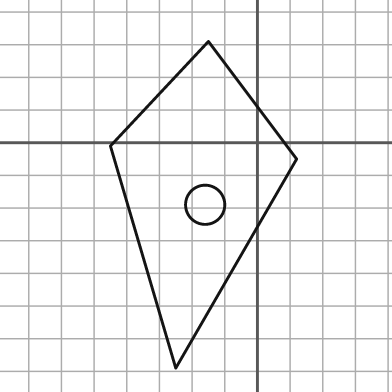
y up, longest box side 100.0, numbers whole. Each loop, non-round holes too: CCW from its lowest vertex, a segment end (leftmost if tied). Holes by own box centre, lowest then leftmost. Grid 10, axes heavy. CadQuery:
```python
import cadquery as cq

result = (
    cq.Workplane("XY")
    .moveTo(-25.0, -69.0)
    .lineTo(12.0, -5.0)
    .lineTo(-15.0, 31.0)
    .lineTo(-45.0, -1.0)
    .close()
    .moveTo(-16.0, -19.0)
    .circle(6.0)
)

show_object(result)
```